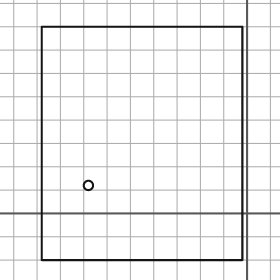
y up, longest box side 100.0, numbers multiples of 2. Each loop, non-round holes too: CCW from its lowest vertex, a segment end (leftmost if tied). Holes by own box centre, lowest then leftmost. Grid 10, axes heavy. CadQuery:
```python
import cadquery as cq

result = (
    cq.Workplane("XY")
    .moveTo(-88.0, -20.0)
    .lineTo(-2.0, -20.0)
    .lineTo(-2.0, 80.0)
    .lineTo(-88.0, 80.0)
    .close()
    .moveTo(-68.0, 12.0)
    .circle(2.0)
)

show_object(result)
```